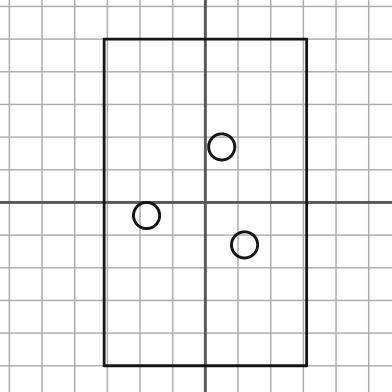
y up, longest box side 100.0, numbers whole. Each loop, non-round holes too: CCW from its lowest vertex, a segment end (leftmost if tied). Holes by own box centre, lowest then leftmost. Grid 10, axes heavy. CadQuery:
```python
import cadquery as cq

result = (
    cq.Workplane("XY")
    .moveTo(-31.0, -50.0)
    .lineTo(31.0, -50.0)
    .lineTo(31.0, 50.0)
    .lineTo(-31.0, 50.0)
    .close()
    .moveTo(12.0, -13.0)
    .circle(4.0)
    .moveTo(-18.0, -4.0)
    .circle(4.0)
    .moveTo(5.0, 17.0)
    .circle(4.0)
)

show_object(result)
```